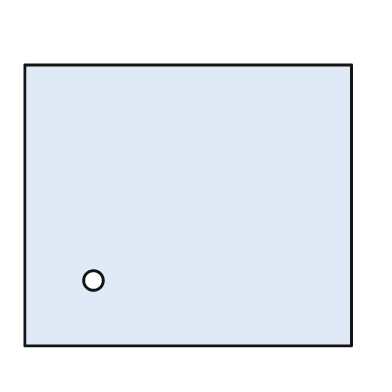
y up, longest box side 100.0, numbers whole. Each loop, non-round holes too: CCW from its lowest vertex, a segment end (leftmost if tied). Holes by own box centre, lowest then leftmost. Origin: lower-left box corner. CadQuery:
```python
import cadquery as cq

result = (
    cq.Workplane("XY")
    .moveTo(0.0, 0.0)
    .lineTo(100.0, 0.0)
    .lineTo(100.0, 86.0)
    .lineTo(0.0, 86.0)
    .close()
    .moveTo(21.0, 20.0)
    .circle(3.0)
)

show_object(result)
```